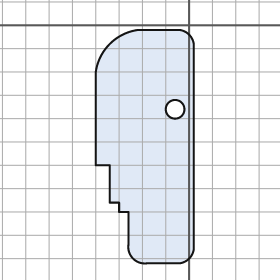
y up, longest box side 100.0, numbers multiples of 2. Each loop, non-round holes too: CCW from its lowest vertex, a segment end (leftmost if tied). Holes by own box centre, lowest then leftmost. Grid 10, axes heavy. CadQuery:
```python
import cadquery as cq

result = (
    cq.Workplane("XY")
    .moveTo(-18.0, -102.0)
    .lineTo(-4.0, -102.0)
    .threePointArc((0.0, -100.0), (2.0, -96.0))
    .lineTo(2.0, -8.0)
    .threePointArc((0.0, -4.0), (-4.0, -2.0))
    .lineTo(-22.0, -2.0)
    .threePointArc((-34.0, -8.0), (-40.0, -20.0))
    .lineTo(-40.0, -60.0)
    .lineTo(-34.0, -60.0)
    .lineTo(-34.0, -76.0)
    .lineTo(-30.0, -76.0)
    .lineTo(-30.0, -80.0)
    .lineTo(-26.0, -80.0)
    .lineTo(-26.0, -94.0)
    .threePointArc((-24.0, -100.0), (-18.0, -102.0))
    .close()
    .moveTo(-6.0, -36.0)
    .circle(4.0)
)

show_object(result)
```